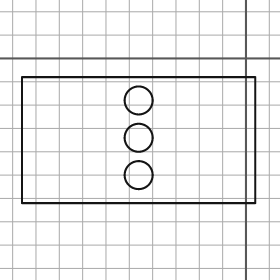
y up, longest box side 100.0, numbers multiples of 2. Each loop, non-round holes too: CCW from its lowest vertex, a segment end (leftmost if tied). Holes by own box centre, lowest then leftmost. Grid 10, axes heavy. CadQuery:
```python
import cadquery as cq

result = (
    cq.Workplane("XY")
    .moveTo(-96.0, -62.0)
    .lineTo(4.0, -62.0)
    .lineTo(4.0, -8.0)
    .lineTo(-96.0, -8.0)
    .close()
    .moveTo(-46.0, -50.0)
    .circle(6.0)
    .moveTo(-46.0, -34.0)
    .circle(6.0)
    .moveTo(-46.0, -18.0)
    .circle(6.0)
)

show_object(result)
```